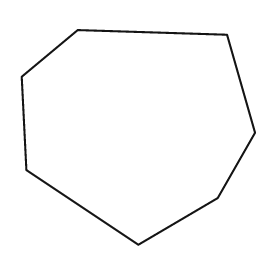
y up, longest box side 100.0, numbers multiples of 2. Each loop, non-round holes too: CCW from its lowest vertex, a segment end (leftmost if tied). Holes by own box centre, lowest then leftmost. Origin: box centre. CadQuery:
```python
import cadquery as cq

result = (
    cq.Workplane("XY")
    .moveTo(0.0, -46.0)
    .lineTo(34.0, -26.0)
    .lineTo(50.0, 2.0)
    .lineTo(38.0, 44.0)
    .lineTo(-26.0, 46.0)
    .lineTo(-50.0, 26.0)
    .lineTo(-48.0, -14.0)
    .close()
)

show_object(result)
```